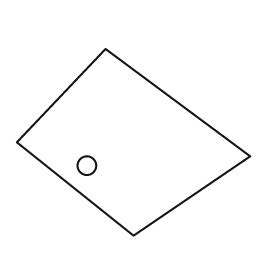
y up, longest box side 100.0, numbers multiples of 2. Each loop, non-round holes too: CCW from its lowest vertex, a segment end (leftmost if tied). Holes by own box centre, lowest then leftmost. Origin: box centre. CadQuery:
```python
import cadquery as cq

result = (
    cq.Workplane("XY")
    .moveTo(0.0, -40.0)
    .lineTo(50.0, -6.0)
    .lineTo(-12.0, 40.0)
    .lineTo(-50.0, 0.0)
    .close()
    .moveTo(-20.0, -10.0)
    .circle(4.0)
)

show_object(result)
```